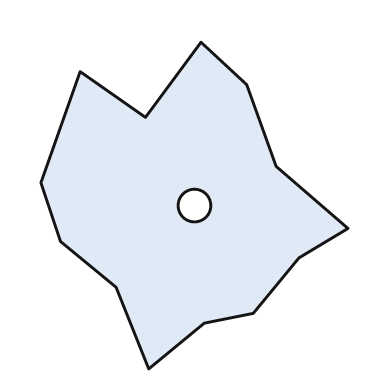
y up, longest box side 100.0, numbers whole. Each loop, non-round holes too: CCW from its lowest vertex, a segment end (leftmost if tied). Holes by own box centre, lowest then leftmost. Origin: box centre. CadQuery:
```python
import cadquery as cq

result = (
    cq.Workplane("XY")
    .moveTo(-14.0, -50.0)
    .lineTo(3.0, -36.0)
    .lineTo(18.0, -33.0)
    .lineTo(32.0, -16.0)
    .lineTo(47.0, -7.0)
    .lineTo(25.0, 12.0)
    .lineTo(16.0, 37.0)
    .lineTo(2.0, 50.0)
    .lineTo(-15.0, 27.0)
    .lineTo(-35.0, 41.0)
    .lineTo(-47.0, 7.0)
    .lineTo(-41.0, -11.0)
    .lineTo(-24.0, -25.0)
    .close()
    .moveTo(0.0, 0.0)
    .circle(5.0)
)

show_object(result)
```